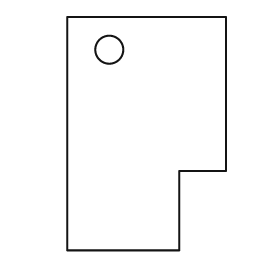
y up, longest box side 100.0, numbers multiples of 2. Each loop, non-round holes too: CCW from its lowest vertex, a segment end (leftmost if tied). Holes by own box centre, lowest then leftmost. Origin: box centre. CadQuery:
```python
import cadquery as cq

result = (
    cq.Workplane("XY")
    .moveTo(-34.0, -50.0)
    .lineTo(14.0, -50.0)
    .lineTo(14.0, -16.0)
    .lineTo(34.0, -16.0)
    .lineTo(34.0, 50.0)
    .lineTo(-34.0, 50.0)
    .close()
    .moveTo(-16.0, 36.0)
    .circle(6.0)
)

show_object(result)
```